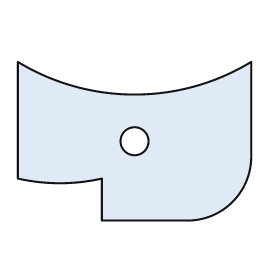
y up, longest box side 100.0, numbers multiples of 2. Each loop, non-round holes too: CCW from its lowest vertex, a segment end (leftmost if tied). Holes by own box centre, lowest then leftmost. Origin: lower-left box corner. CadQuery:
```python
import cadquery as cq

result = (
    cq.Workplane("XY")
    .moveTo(36.0, 0.0)
    .lineTo(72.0, 0.0)
    .threePointArc((92.0, 8.0), (100.0, 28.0))
    .lineTo(100.0, 68.0)
    .threePointArc((50.0, 54.0), (0.0, 68.0))
    .lineTo(0.0, 18.0)
    .threePointArc((18.0, 16.0), (36.0, 18.0))
    .close()
    .moveTo(50.0, 34.0)
    .circle(6.0)
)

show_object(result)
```